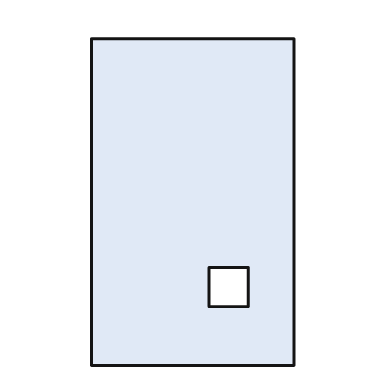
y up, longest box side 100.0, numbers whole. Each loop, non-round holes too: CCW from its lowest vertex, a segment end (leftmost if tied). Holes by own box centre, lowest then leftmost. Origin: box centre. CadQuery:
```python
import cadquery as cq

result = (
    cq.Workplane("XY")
    .moveTo(-31.0, -50.0)
    .lineTo(31.0, -50.0)
    .lineTo(31.0, 50.0)
    .lineTo(-31.0, 50.0)
    .close()
    .moveTo(5.0, -32.0)
    .lineTo(17.0, -32.0)
    .lineTo(17.0, -20.0)
    .lineTo(5.0, -20.0)
    .close()
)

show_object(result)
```